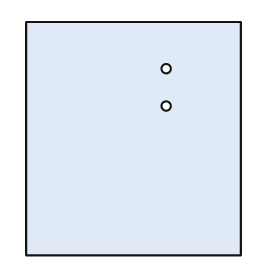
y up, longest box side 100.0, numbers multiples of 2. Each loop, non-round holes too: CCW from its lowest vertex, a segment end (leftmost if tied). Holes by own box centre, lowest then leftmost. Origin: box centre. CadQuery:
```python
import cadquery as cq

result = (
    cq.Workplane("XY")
    .moveTo(-46.0, -50.0)
    .lineTo(46.0, -50.0)
    .lineTo(46.0, 50.0)
    .lineTo(-46.0, 50.0)
    .close()
    .moveTo(14.0, 14.0)
    .circle(2.0)
    .moveTo(14.0, 30.0)
    .circle(2.0)
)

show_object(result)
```